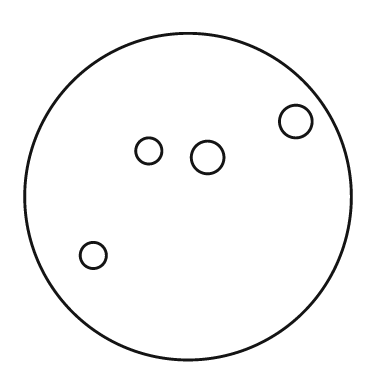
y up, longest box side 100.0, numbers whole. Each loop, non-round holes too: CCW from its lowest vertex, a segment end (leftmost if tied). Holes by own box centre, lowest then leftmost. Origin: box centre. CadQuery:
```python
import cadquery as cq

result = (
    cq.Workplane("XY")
    .moveTo(0.0, 0.0)
    .circle(50.0)
    .moveTo(-29.0, -18.0)
    .circle(4.0)
    .moveTo(6.0, 12.0)
    .circle(5.0)
    .moveTo(-12.0, 14.0)
    .circle(4.0)
    .moveTo(33.0, 23.0)
    .circle(5.0)
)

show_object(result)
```